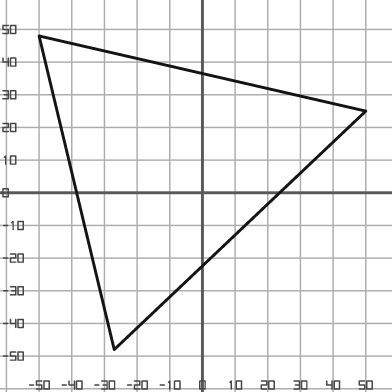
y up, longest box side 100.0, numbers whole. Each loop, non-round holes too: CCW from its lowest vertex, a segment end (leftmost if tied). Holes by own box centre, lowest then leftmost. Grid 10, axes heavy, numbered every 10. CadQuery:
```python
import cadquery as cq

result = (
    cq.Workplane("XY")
    .moveTo(-27.0, -48.0)
    .lineTo(50.0, 25.0)
    .lineTo(-50.0, 48.0)
    .close()
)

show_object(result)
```